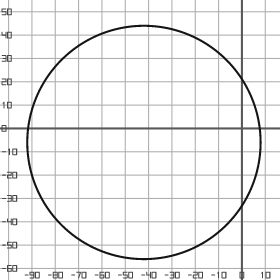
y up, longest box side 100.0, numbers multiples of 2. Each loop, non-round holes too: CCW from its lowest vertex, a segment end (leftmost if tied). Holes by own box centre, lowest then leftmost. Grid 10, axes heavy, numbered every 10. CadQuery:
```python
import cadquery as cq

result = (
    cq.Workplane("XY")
    .moveTo(-42.0, -6.0)
    .circle(50.0)
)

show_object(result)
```